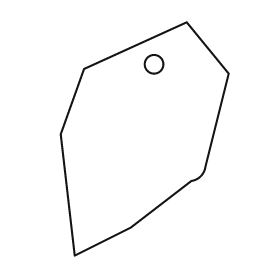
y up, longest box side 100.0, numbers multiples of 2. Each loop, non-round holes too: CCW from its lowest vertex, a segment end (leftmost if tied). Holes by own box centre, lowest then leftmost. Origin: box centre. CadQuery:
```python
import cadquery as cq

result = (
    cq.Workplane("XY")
    .moveTo(-30.0, -50.0)
    .lineTo(-6.0, -38.0)
    .lineTo(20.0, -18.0)
    .threePointArc((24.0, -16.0), (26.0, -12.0))
    .lineTo(36.0, 28.0)
    .lineTo(18.0, 50.0)
    .lineTo(-26.0, 30.0)
    .lineTo(-36.0, 2.0)
    .close()
    .moveTo(4.0, 32.0)
    .circle(4.0)
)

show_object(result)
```